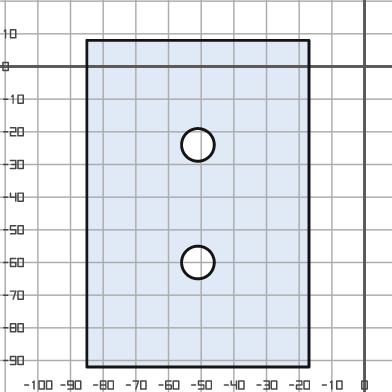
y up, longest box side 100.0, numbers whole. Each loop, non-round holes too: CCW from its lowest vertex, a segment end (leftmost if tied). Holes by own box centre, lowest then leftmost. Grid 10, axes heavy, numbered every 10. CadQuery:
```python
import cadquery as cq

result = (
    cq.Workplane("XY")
    .moveTo(-85.0, -92.0)
    .lineTo(-17.0, -92.0)
    .lineTo(-17.0, 8.0)
    .lineTo(-85.0, 8.0)
    .close()
    .moveTo(-51.0, -60.0)
    .circle(5.0)
    .moveTo(-51.0, -24.0)
    .circle(5.0)
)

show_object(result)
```